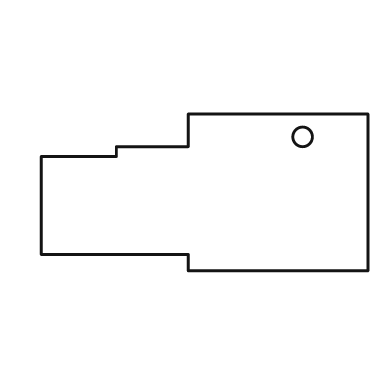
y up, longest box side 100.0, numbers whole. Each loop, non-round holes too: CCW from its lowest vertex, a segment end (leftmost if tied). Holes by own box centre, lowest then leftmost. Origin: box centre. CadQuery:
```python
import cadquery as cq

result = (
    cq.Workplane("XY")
    .moveTo(-5.0, -24.0)
    .lineTo(50.0, -24.0)
    .lineTo(50.0, 24.0)
    .lineTo(-5.0, 24.0)
    .lineTo(-5.0, 14.0)
    .lineTo(-27.0, 14.0)
    .lineTo(-27.0, 11.0)
    .lineTo(-50.0, 11.0)
    .lineTo(-50.0, -19.0)
    .lineTo(-5.0, -19.0)
    .close()
    .moveTo(30.0, 17.0)
    .circle(3.0)
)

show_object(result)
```